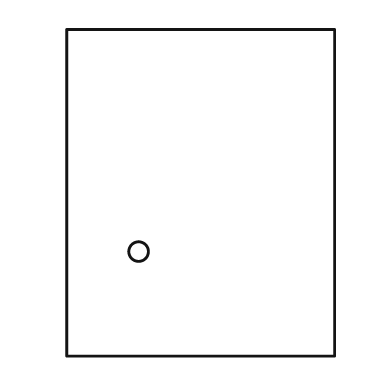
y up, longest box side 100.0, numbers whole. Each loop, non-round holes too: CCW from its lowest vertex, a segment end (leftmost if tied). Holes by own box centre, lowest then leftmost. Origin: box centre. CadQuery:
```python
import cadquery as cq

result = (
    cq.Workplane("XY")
    .moveTo(-41.0, -50.0)
    .lineTo(41.0, -50.0)
    .lineTo(41.0, 50.0)
    .lineTo(-41.0, 50.0)
    .close()
    .moveTo(-19.0, -18.0)
    .circle(3.0)
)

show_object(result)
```